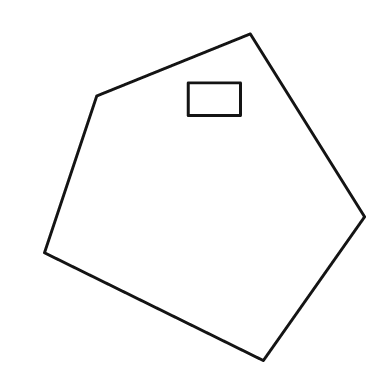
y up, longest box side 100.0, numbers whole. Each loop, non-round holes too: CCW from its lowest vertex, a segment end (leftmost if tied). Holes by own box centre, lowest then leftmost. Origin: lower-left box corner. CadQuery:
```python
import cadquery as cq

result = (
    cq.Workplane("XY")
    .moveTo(67.0, 0.0)
    .lineTo(98.0, 44.0)
    .lineTo(63.0, 100.0)
    .lineTo(16.0, 81.0)
    .lineTo(0.0, 33.0)
    .close()
    .moveTo(44.0, 75.0)
    .lineTo(60.0, 75.0)
    .lineTo(60.0, 85.0)
    .lineTo(44.0, 85.0)
    .close()
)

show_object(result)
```